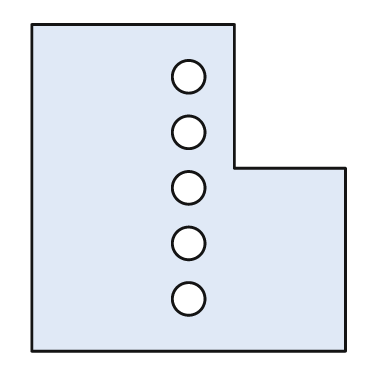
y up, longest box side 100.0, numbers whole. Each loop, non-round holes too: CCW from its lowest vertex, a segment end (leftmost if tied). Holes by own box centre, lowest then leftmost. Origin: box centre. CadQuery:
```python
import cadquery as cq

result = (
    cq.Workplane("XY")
    .moveTo(-48.0, -50.0)
    .lineTo(48.0, -50.0)
    .lineTo(48.0, 6.0)
    .lineTo(14.0, 6.0)
    .lineTo(14.0, 50.0)
    .lineTo(-48.0, 50.0)
    .close()
    .moveTo(0.0, -34.0)
    .circle(5.0)
    .moveTo(0.0, -17.0)
    .circle(5.0)
    .moveTo(0.0, 0.0)
    .circle(5.0)
    .moveTo(0.0, 17.0)
    .circle(5.0)
    .moveTo(0.0, 34.0)
    .circle(5.0)
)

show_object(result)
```